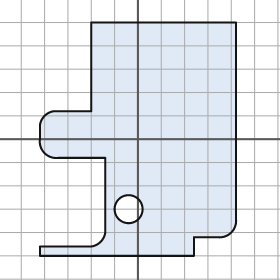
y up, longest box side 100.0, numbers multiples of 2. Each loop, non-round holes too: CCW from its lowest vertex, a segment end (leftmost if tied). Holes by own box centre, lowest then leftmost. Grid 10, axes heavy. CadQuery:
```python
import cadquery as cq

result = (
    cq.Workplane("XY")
    .moveTo(-42.0, -50.0)
    .lineTo(24.0, -50.0)
    .lineTo(24.0, -42.0)
    .lineTo(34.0, -42.0)
    .threePointArc((40.0, -40.0), (42.0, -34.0))
    .lineTo(42.0, 50.0)
    .lineTo(-20.0, 50.0)
    .lineTo(-20.0, 12.0)
    .lineTo(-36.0, 12.0)
    .threePointArc((-40.0, 10.0), (-42.0, 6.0))
    .lineTo(-42.0, 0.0)
    .threePointArc((-40.0, -6.0), (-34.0, -8.0))
    .lineTo(-14.0, -8.0)
    .lineTo(-14.0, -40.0)
    .threePointArc((-16.0, -44.0), (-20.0, -46.0))
    .lineTo(-42.0, -46.0)
    .close()
    .moveTo(-4.0, -30.0)
    .circle(6.0)
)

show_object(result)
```